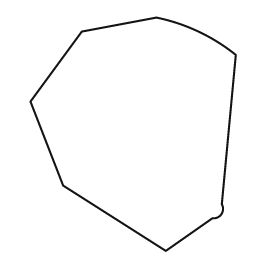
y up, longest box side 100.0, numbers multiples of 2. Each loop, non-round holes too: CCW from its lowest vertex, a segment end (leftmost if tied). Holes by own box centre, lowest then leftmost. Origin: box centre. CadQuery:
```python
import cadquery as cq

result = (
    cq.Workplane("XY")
    .moveTo(14.0, -50.0)
    .lineTo(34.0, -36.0)
    .threePointArc((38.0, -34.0), (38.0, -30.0))
    .lineTo(44.0, 34.0)
    .threePointArc((28.0, 44.0), (10.0, 50.0))
    .lineTo(-22.0, 44.0)
    .lineTo(-44.0, 14.0)
    .lineTo(-30.0, -22.0)
    .close()
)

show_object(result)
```